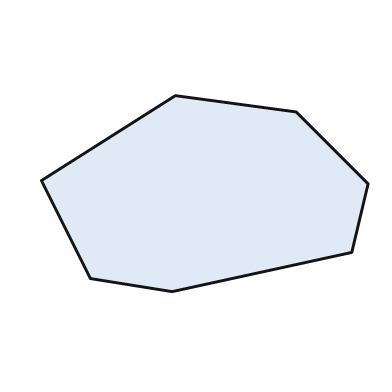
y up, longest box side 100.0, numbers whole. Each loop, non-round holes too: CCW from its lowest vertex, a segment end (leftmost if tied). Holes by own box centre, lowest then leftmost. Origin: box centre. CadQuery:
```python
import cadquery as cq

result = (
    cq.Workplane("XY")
    .moveTo(-10.0, -30.0)
    .lineTo(45.0, -18.0)
    .lineTo(50.0, 3.0)
    .lineTo(28.0, 25.0)
    .lineTo(-9.0, 30.0)
    .lineTo(-50.0, 4.0)
    .lineTo(-35.0, -26.0)
    .close()
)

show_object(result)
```